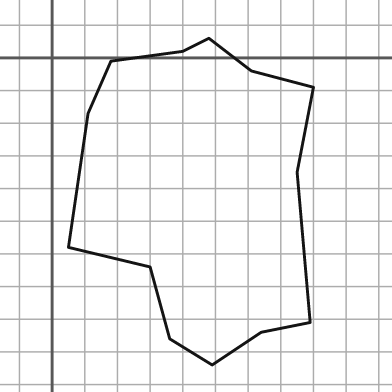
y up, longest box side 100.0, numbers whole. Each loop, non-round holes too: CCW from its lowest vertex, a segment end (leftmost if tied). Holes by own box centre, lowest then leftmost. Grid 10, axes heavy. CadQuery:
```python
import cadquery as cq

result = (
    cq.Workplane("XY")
    .moveTo(49.0, -94.0)
    .lineTo(64.0, -84.0)
    .lineTo(79.0, -81.0)
    .lineTo(75.0, -35.0)
    .lineTo(80.0, -9.0)
    .lineTo(61.0, -4.0)
    .lineTo(48.0, 6.0)
    .lineTo(40.0, 2.0)
    .lineTo(18.0, -1.0)
    .lineTo(11.0, -17.0)
    .lineTo(5.0, -58.0)
    .lineTo(30.0, -64.0)
    .lineTo(36.0, -86.0)
    .close()
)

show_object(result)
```